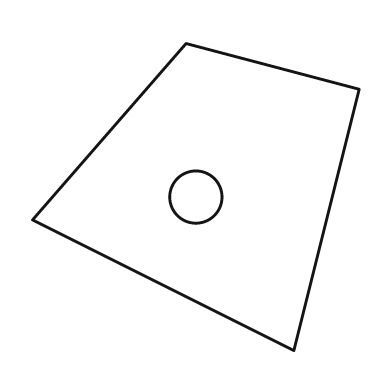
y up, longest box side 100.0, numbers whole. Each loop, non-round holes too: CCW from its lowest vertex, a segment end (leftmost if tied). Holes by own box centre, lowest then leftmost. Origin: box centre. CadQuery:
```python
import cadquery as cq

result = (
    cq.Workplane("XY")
    .moveTo(30.0, -47.0)
    .lineTo(50.0, 33.0)
    .lineTo(-3.0, 47.0)
    .lineTo(-50.0, -7.0)
    .close()
    .moveTo(0.0, 0.0)
    .circle(8.0)
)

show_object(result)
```